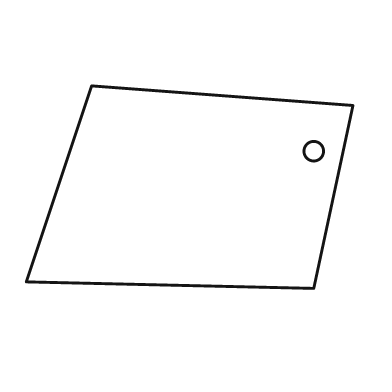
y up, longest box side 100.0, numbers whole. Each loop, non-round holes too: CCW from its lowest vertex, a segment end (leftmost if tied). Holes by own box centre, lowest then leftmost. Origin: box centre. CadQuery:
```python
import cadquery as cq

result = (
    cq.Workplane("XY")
    .moveTo(38.0, -31.0)
    .lineTo(50.0, 25.0)
    .lineTo(-30.0, 31.0)
    .lineTo(-50.0, -29.0)
    .close()
    .moveTo(38.0, 11.0)
    .circle(3.0)
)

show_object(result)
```